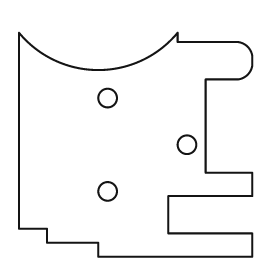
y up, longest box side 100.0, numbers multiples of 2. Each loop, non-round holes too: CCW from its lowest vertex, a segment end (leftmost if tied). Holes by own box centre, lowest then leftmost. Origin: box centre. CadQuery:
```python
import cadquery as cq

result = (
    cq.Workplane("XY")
    .moveTo(-16.0, -48.0)
    .lineTo(50.0, -48.0)
    .lineTo(50.0, -38.0)
    .lineTo(14.0, -38.0)
    .lineTo(14.0, -22.0)
    .lineTo(50.0, -22.0)
    .lineTo(50.0, -12.0)
    .lineTo(30.0, -12.0)
    .lineTo(30.0, 28.0)
    .lineTo(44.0, 28.0)
    .threePointArc((48.0, 30.0), (50.0, 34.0))
    .lineTo(50.0, 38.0)
    .threePointArc((48.0, 42.0), (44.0, 44.0))
    .lineTo(18.0, 44.0)
    .lineTo(18.0, 48.0)
    .threePointArc((-16.0, 32.0), (-50.0, 48.0))
    .lineTo(-50.0, -36.0)
    .lineTo(-38.0, -36.0)
    .lineTo(-38.0, -42.0)
    .lineTo(-16.0, -42.0)
    .close()
    .moveTo(-12.0, -20.0)
    .circle(4.0)
    .moveTo(22.0, 0.0)
    .circle(4.0)
    .moveTo(-12.0, 20.0)
    .circle(4.0)
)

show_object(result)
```